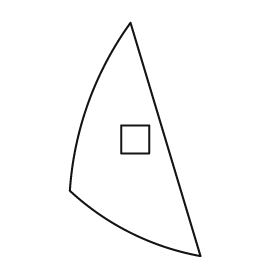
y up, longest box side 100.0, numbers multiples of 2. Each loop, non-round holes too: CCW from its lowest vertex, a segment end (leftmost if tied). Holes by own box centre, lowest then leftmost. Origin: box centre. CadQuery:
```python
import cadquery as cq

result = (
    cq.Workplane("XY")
    .moveTo(28.0, -50.0)
    .lineTo(-2.0, 50.0)
    .threePointArc((-20.0, 16.0), (-28.0, -22.0))
    .threePointArc((-2.0, -40.0), (28.0, -50.0))
    .close()
    .moveTo(-6.0, -6.0)
    .lineTo(6.0, -6.0)
    .lineTo(6.0, 6.0)
    .lineTo(-6.0, 6.0)
    .close()
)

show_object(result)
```